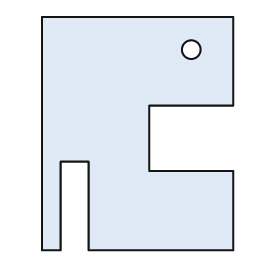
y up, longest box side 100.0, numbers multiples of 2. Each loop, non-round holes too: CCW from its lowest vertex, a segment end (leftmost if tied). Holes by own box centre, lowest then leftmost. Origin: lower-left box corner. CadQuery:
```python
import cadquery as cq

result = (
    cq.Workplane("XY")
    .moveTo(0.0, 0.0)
    .lineTo(8.0, 0.0)
    .lineTo(8.0, 38.0)
    .lineTo(20.0, 38.0)
    .lineTo(20.0, 0.0)
    .lineTo(82.0, 0.0)
    .lineTo(82.0, 34.0)
    .lineTo(46.0, 34.0)
    .lineTo(46.0, 62.0)
    .lineTo(82.0, 62.0)
    .lineTo(82.0, 100.0)
    .lineTo(0.0, 100.0)
    .close()
    .moveTo(64.0, 86.0)
    .circle(4.0)
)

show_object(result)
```